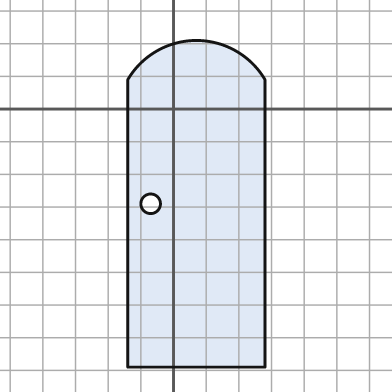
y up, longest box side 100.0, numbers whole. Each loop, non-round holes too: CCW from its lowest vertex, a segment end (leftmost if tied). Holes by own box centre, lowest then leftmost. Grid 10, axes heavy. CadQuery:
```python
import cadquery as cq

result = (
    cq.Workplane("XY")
    .moveTo(-14.0, -79.0)
    .lineTo(28.0, -79.0)
    .lineTo(28.0, 9.0)
    .threePointArc((7.0, 21.0), (-14.0, 9.0))
    .close()
    .moveTo(-7.0, -29.0)
    .circle(3.0)
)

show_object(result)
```